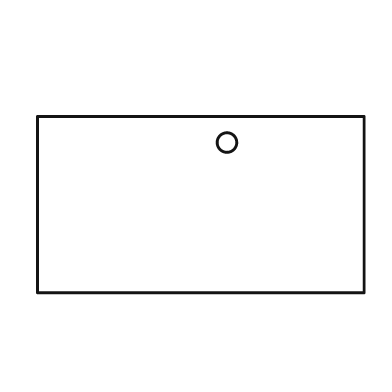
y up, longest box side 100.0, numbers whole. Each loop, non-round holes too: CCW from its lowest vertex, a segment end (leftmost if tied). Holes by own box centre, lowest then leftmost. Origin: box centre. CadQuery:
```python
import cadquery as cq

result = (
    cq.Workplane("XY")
    .moveTo(-50.0, -27.0)
    .lineTo(50.0, -27.0)
    .lineTo(50.0, 27.0)
    .lineTo(-50.0, 27.0)
    .close()
    .moveTo(8.0, 19.0)
    .circle(3.0)
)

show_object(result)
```